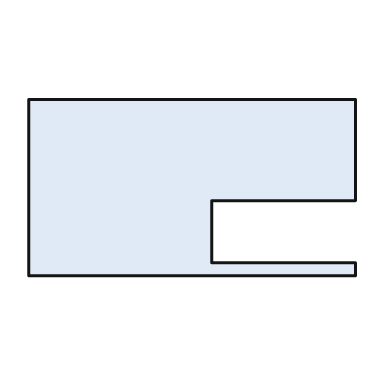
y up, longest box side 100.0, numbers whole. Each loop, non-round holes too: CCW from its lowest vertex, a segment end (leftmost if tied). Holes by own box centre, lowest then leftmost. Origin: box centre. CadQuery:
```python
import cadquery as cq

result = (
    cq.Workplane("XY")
    .moveTo(-50.0, -27.0)
    .lineTo(50.0, -27.0)
    .lineTo(50.0, -23.0)
    .lineTo(6.0, -23.0)
    .lineTo(6.0, -4.0)
    .lineTo(50.0, -4.0)
    .lineTo(50.0, 27.0)
    .lineTo(-50.0, 27.0)
    .close()
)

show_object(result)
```